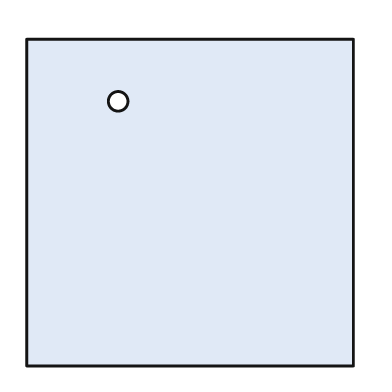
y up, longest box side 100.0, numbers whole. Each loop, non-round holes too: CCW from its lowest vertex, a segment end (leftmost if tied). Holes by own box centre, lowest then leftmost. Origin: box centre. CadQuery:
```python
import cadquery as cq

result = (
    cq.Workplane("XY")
    .moveTo(-50.0, -50.0)
    .lineTo(50.0, -50.0)
    .lineTo(50.0, 50.0)
    .lineTo(-50.0, 50.0)
    .close()
    .moveTo(-22.0, 31.0)
    .circle(3.0)
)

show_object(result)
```